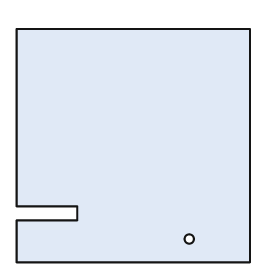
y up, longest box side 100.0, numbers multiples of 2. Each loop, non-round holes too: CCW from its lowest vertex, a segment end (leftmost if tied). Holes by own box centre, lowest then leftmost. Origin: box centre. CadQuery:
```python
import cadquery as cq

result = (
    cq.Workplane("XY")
    .moveTo(-50.0, -50.0)
    .lineTo(50.0, -50.0)
    .lineTo(50.0, 50.0)
    .lineTo(-50.0, 50.0)
    .lineTo(-50.0, -26.0)
    .lineTo(-24.0, -26.0)
    .lineTo(-24.0, -32.0)
    .lineTo(-50.0, -32.0)
    .close()
    .moveTo(24.0, -40.0)
    .circle(2.0)
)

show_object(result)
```